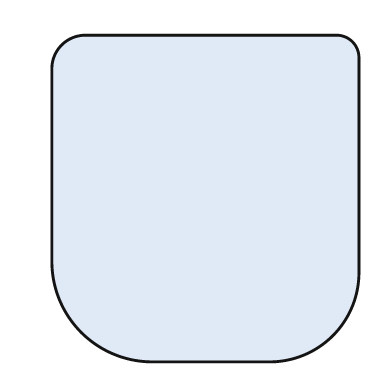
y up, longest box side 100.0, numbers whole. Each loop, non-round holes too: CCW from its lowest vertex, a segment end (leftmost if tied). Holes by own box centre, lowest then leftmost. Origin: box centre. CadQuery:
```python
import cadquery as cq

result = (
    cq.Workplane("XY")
    .moveTo(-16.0, -50.0)
    .lineTo(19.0, -50.0)
    .threePointArc((39.0, -42.0), (47.0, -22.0))
    .lineTo(47.0, 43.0)
    .threePointArc((45.0, 48.0), (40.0, 50.0))
    .lineTo(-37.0, 50.0)
    .threePointArc((-44.0, 47.0), (-47.0, 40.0))
    .lineTo(-47.0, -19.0)
    .threePointArc((-38.0, -41.0), (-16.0, -50.0))
    .close()
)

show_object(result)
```